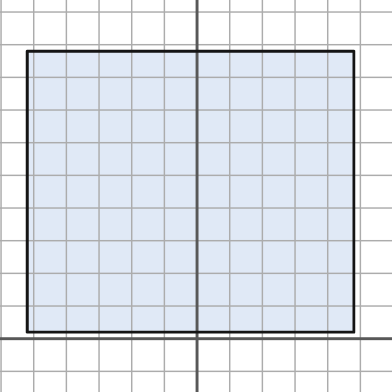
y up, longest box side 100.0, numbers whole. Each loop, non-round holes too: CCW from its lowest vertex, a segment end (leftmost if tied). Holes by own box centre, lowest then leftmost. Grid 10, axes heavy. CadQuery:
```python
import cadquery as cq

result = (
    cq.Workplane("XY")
    .moveTo(-52.0, 2.0)
    .lineTo(48.0, 2.0)
    .lineTo(48.0, 88.0)
    .lineTo(-52.0, 88.0)
    .close()
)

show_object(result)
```